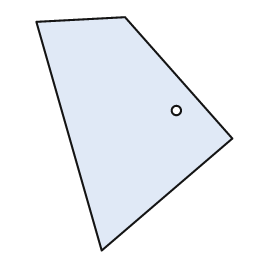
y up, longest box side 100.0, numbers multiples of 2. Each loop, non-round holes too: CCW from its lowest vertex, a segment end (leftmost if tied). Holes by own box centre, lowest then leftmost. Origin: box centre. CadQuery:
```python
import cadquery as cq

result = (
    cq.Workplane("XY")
    .moveTo(-14.0, -50.0)
    .lineTo(42.0, -2.0)
    .lineTo(-4.0, 50.0)
    .lineTo(-42.0, 48.0)
    .close()
    .moveTo(18.0, 10.0)
    .circle(2.0)
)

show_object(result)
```